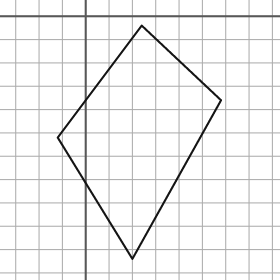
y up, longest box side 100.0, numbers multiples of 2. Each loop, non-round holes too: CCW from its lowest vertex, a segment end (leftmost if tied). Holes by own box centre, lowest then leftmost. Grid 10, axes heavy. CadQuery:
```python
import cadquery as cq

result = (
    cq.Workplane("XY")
    .moveTo(20.0, -104.0)
    .lineTo(58.0, -36.0)
    .lineTo(24.0, -4.0)
    .lineTo(-12.0, -52.0)
    .close()
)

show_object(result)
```